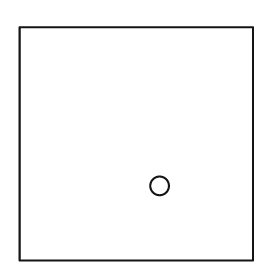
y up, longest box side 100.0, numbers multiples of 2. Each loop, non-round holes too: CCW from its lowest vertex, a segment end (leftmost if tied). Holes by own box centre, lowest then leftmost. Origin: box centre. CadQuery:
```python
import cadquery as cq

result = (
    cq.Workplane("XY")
    .moveTo(-50.0, -50.0)
    .lineTo(50.0, -50.0)
    .lineTo(50.0, 50.0)
    .lineTo(-50.0, 50.0)
    .close()
    .moveTo(10.0, -18.0)
    .circle(4.0)
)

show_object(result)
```